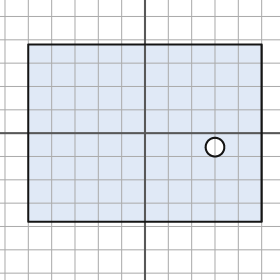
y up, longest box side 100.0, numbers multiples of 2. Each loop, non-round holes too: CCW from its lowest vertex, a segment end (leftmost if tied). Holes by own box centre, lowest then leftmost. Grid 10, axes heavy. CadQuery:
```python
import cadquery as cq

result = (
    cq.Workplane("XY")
    .moveTo(-50.0, -38.0)
    .lineTo(50.0, -38.0)
    .lineTo(50.0, 38.0)
    .lineTo(-50.0, 38.0)
    .close()
    .moveTo(30.0, -6.0)
    .circle(4.0)
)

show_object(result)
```